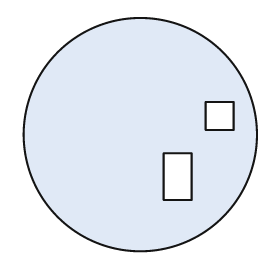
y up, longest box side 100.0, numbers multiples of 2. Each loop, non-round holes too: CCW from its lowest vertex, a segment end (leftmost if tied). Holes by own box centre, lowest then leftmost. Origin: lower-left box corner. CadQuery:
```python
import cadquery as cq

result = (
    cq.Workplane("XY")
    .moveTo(50.0, 50.0)
    .circle(50.0)
    .moveTo(60.0, 22.0)
    .lineTo(72.0, 22.0)
    .lineTo(72.0, 42.0)
    .lineTo(60.0, 42.0)
    .close()
    .moveTo(78.0, 52.0)
    .lineTo(90.0, 52.0)
    .lineTo(90.0, 64.0)
    .lineTo(78.0, 64.0)
    .close()
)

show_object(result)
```